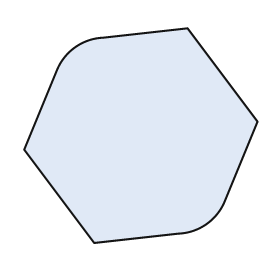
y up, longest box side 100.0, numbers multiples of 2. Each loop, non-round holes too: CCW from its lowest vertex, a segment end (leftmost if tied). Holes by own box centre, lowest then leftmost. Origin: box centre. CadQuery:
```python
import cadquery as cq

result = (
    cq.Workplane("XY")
    .moveTo(-20.0, -46.0)
    .lineTo(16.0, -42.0)
    .threePointArc((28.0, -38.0), (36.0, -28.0))
    .lineTo(50.0, 6.0)
    .lineTo(20.0, 46.0)
    .lineTo(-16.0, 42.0)
    .threePointArc((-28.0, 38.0), (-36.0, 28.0))
    .lineTo(-50.0, -6.0)
    .close()
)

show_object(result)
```